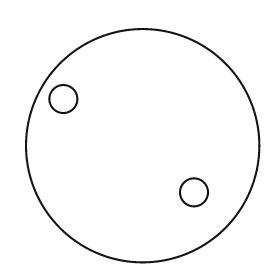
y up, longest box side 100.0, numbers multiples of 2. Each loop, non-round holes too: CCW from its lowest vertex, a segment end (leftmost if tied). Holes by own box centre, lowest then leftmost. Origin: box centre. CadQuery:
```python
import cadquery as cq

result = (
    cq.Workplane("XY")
    .moveTo(0.0, 0.0)
    .circle(50.0)
    .moveTo(22.0, -20.0)
    .circle(6.0)
    .moveTo(-34.0, 20.0)
    .circle(6.0)
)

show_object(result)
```